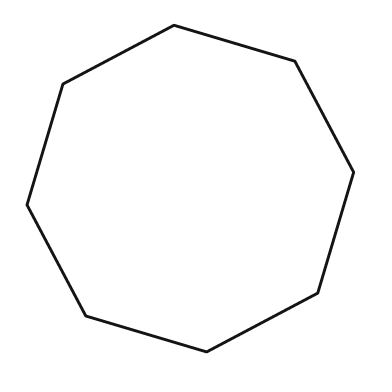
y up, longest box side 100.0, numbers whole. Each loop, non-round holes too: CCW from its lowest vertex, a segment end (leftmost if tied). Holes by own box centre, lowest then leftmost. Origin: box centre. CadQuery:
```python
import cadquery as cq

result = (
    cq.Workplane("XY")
    .moveTo(5.0, -50.0)
    .lineTo(39.0, -32.0)
    .lineTo(50.0, 5.0)
    .lineTo(32.0, 39.0)
    .lineTo(-5.0, 50.0)
    .lineTo(-39.0, 32.0)
    .lineTo(-50.0, -5.0)
    .lineTo(-32.0, -39.0)
    .close()
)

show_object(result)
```